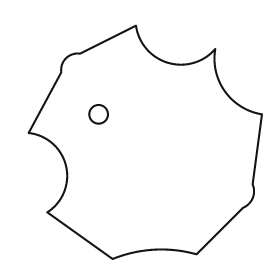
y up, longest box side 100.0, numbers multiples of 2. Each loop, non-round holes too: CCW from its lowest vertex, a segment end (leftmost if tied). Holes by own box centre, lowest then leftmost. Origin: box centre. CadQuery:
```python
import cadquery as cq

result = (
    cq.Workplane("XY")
    .moveTo(-14.0, -50.0)
    .threePointArc((4.0, -46.0), (22.0, -48.0))
    .lineTo(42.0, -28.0)
    .threePointArc((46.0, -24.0), (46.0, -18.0))
    .lineTo(50.0, 12.0)
    .threePointArc((34.0, 22.0), (30.0, 40.0))
    .threePointArc((10.0, 34.0), (-4.0, 50.0))
    .lineTo(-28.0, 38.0)
    .threePointArc((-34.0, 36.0), (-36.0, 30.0))
    .lineTo(-50.0, 4.0)
    .threePointArc((-34.0, -10.0), (-42.0, -30.0))
    .close()
    .moveTo(-20.0, 12.0)
    .circle(4.0)
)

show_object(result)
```